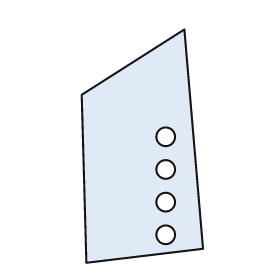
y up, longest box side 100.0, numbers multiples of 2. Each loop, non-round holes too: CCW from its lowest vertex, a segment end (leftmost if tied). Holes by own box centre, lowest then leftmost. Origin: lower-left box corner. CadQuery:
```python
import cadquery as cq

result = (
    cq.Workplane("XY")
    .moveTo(2.0, 0.0)
    .lineTo(52.0, 6.0)
    .lineTo(44.0, 100.0)
    .lineTo(0.0, 72.0)
    .close()
    .moveTo(36.0, 12.0)
    .circle(4.0)
    .moveTo(36.0, 26.0)
    .circle(4.0)
    .moveTo(36.0, 40.0)
    .circle(4.0)
    .moveTo(36.0, 54.0)
    .circle(4.0)
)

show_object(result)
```